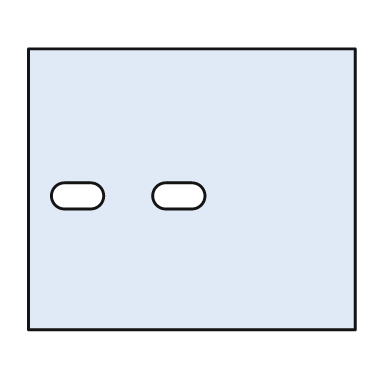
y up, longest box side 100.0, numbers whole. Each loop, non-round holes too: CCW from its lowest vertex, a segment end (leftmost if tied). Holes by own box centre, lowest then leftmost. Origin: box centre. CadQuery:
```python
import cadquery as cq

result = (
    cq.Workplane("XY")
    .moveTo(-50.0, -43.0)
    .lineTo(50.0, -43.0)
    .lineTo(50.0, 43.0)
    .lineTo(-50.0, 43.0)
    .close()
    .moveTo(-39.0, -6.0)
    .lineTo(-31.0, -6.0)
    .threePointArc((-27.0, -2.0), (-31.0, 2.0))
    .lineTo(-39.0, 2.0)
    .threePointArc((-43.0, -2.0), (-39.0, -6.0))
    .close()
    .moveTo(-8.0, -6.0)
    .lineTo(0.0, -6.0)
    .threePointArc((4.0, -2.0), (0.0, 2.0))
    .lineTo(-8.0, 2.0)
    .threePointArc((-12.0, -2.0), (-8.0, -6.0))
    .close()
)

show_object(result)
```